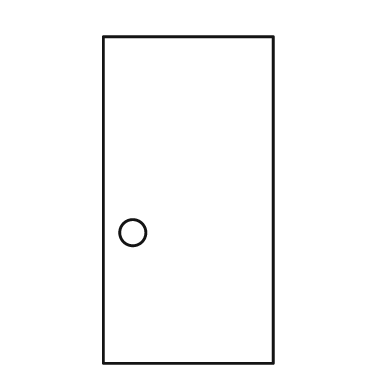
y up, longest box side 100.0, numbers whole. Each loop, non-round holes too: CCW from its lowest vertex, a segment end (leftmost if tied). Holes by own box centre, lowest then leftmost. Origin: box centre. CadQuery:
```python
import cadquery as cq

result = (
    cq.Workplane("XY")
    .moveTo(-26.0, -50.0)
    .lineTo(26.0, -50.0)
    .lineTo(26.0, 50.0)
    .lineTo(-26.0, 50.0)
    .close()
    .moveTo(-17.0, -10.0)
    .circle(4.0)
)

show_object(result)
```